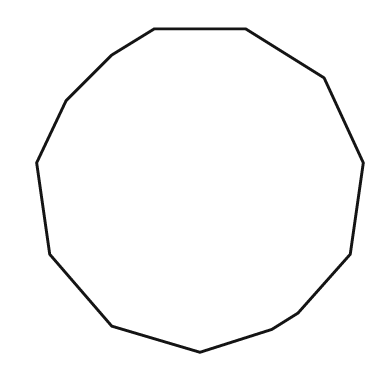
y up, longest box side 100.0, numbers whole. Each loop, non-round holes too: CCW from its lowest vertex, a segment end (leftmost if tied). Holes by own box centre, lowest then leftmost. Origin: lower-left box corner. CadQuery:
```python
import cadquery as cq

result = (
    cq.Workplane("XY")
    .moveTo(50.0, 0.0)
    .lineTo(72.0, 7.0)
    .lineTo(80.0, 12.0)
    .lineTo(96.0, 30.0)
    .lineTo(100.0, 58.0)
    .lineTo(88.0, 84.0)
    .lineTo(64.0, 99.0)
    .lineTo(36.0, 99.0)
    .lineTo(23.0, 91.0)
    .lineTo(9.0, 77.0)
    .lineTo(0.0, 58.0)
    .lineTo(4.0, 30.0)
    .lineTo(23.0, 8.0)
    .close()
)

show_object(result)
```